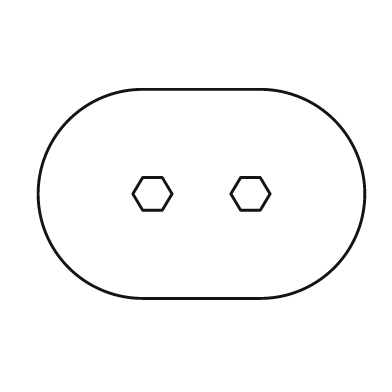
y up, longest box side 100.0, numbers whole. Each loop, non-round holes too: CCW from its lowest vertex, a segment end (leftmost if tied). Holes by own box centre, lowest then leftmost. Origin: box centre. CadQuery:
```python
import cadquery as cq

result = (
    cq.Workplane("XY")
    .moveTo(-18.0, -32.0)
    .lineTo(18.0, -32.0)
    .threePointArc((50.0, 0.0), (18.0, 32.0))
    .lineTo(-18.0, 32.0)
    .threePointArc((-50.0, 0.0), (-18.0, -32.0))
    .close()
    .moveTo(-18.0, -5.0)
    .lineTo(-12.0, -5.0)
    .lineTo(-9.0, 0.0)
    .lineTo(-12.0, 5.0)
    .lineTo(-18.0, 5.0)
    .lineTo(-21.0, 0.0)
    .close()
    .moveTo(12.0, -5.0)
    .lineTo(18.0, -5.0)
    .lineTo(21.0, 0.0)
    .lineTo(18.0, 5.0)
    .lineTo(12.0, 5.0)
    .lineTo(9.0, 0.0)
    .close()
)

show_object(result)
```